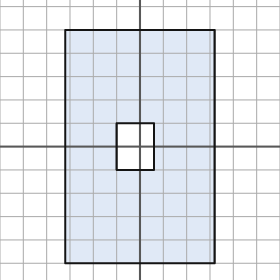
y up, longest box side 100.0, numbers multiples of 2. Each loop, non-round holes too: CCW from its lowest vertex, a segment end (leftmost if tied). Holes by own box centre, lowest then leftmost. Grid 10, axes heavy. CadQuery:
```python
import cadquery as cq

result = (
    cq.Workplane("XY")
    .moveTo(-32.0, -50.0)
    .lineTo(32.0, -50.0)
    .lineTo(32.0, 50.0)
    .lineTo(-32.0, 50.0)
    .close()
    .moveTo(-10.0, -10.0)
    .lineTo(6.0, -10.0)
    .lineTo(6.0, 10.0)
    .lineTo(-10.0, 10.0)
    .close()
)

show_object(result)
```